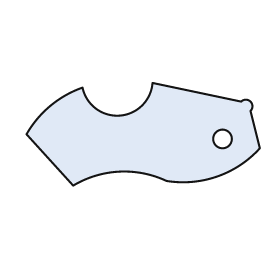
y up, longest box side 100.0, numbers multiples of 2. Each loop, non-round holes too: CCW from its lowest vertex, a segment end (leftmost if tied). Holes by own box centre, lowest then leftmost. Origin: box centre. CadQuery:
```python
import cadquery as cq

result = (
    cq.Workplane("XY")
    .moveTo(-30.0, -22.0)
    .threePointArc((-10.0, -16.0), (10.0, -20.0))
    .threePointArc((32.0, -18.0), (50.0, -6.0))
    .lineTo(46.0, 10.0)
    .threePointArc((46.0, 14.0), (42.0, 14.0))
    .lineTo(4.0, 22.0)
    .threePointArc((-10.0, 8.0), (-26.0, 20.0))
    .threePointArc((-40.0, 12.0), (-50.0, 0.0))
    .close()
    .moveTo(34.0, -2.0)
    .circle(4.0)
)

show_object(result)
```